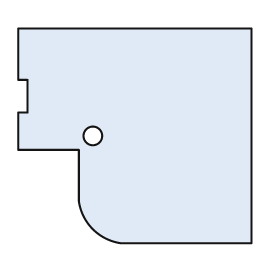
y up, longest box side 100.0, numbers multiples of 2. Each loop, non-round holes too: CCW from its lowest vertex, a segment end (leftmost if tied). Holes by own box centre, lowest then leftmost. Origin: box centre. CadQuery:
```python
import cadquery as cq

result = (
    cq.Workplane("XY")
    .moveTo(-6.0, -46.0)
    .lineTo(50.0, -46.0)
    .lineTo(50.0, 46.0)
    .lineTo(-50.0, 46.0)
    .lineTo(-50.0, 24.0)
    .lineTo(-46.0, 24.0)
    .lineTo(-46.0, 10.0)
    .lineTo(-50.0, 10.0)
    .lineTo(-50.0, -6.0)
    .lineTo(-24.0, -6.0)
    .lineTo(-24.0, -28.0)
    .threePointArc((-18.0, -40.0), (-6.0, -46.0))
    .close()
    .moveTo(-18.0, 0.0)
    .circle(4.0)
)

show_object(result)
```